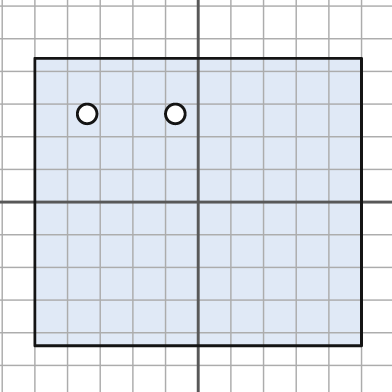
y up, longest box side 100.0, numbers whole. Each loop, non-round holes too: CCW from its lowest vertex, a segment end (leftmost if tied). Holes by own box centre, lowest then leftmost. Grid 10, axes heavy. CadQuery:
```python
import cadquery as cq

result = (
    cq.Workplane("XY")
    .moveTo(-50.0, -44.0)
    .lineTo(50.0, -44.0)
    .lineTo(50.0, 44.0)
    .lineTo(-50.0, 44.0)
    .close()
    .moveTo(-34.0, 27.0)
    .circle(3.0)
    .moveTo(-7.0, 27.0)
    .circle(3.0)
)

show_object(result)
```